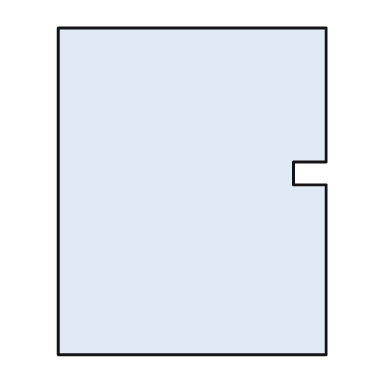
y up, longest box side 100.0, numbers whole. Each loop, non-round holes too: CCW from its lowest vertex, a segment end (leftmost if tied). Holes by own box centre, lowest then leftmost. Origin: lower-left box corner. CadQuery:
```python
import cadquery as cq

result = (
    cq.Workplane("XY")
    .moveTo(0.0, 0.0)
    .lineTo(82.0, 0.0)
    .lineTo(82.0, 52.0)
    .lineTo(72.0, 52.0)
    .lineTo(72.0, 59.0)
    .lineTo(82.0, 59.0)
    .lineTo(82.0, 100.0)
    .lineTo(0.0, 100.0)
    .close()
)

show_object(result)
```